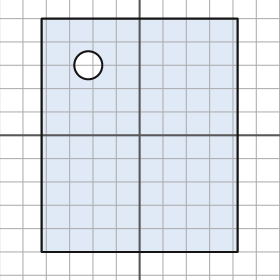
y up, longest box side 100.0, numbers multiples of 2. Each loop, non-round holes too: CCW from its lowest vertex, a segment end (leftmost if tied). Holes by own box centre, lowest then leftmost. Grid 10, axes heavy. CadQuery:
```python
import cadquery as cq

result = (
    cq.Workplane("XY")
    .moveTo(-42.0, -50.0)
    .lineTo(42.0, -50.0)
    .lineTo(42.0, 50.0)
    .lineTo(-42.0, 50.0)
    .close()
    .moveTo(-22.0, 30.0)
    .circle(6.0)
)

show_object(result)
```